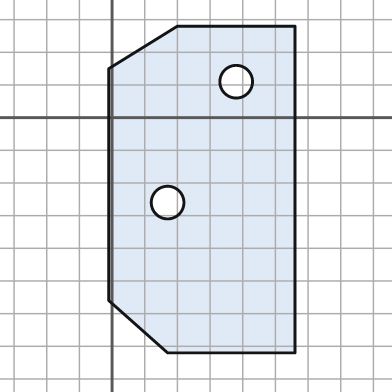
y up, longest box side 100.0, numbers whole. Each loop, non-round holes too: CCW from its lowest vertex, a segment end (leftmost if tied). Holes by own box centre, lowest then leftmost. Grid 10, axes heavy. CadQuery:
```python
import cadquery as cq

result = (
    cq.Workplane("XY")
    .moveTo(17.0, -72.0)
    .lineTo(56.0, -72.0)
    .lineTo(56.0, 28.0)
    .lineTo(20.0, 28.0)
    .lineTo(-1.0, 15.0)
    .lineTo(-1.0, -56.0)
    .close()
    .moveTo(17.0, -26.0)
    .circle(5.0)
    .moveTo(38.0, 11.0)
    .circle(5.0)
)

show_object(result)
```